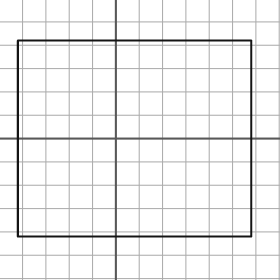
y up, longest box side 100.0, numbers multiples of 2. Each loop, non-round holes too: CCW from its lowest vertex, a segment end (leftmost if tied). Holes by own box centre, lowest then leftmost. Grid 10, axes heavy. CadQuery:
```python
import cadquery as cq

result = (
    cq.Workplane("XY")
    .moveTo(-42.0, -42.0)
    .lineTo(58.0, -42.0)
    .lineTo(58.0, 42.0)
    .lineTo(-42.0, 42.0)
    .close()
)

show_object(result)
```